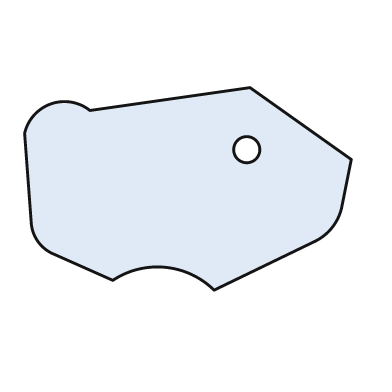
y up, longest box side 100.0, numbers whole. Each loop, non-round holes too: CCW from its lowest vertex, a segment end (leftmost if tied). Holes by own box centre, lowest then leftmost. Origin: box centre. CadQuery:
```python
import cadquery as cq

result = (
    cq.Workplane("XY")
    .moveTo(8.0, -31.0)
    .lineTo(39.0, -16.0)
    .threePointArc((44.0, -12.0), (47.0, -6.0))
    .lineTo(50.0, 9.0)
    .lineTo(19.0, 31.0)
    .lineTo(-30.0, 24.0)
    .threePointArc((-42.0, 26.0), (-50.0, 17.0))
    .lineTo(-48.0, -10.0)
    .threePointArc((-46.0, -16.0), (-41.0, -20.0))
    .lineTo(-23.0, -28.0)
    .threePointArc((-7.0, -24.0), (8.0, -31.0))
    .close()
    .moveTo(18.0, 12.0)
    .circle(4.0)
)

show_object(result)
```